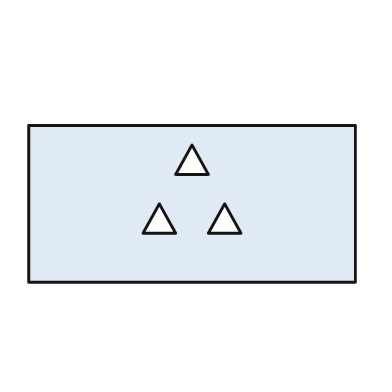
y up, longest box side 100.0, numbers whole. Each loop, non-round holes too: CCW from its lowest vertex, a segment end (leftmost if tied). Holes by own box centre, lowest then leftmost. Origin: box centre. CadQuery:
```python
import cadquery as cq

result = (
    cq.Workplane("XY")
    .moveTo(-50.0, -24.0)
    .lineTo(50.0, -24.0)
    .lineTo(50.0, 24.0)
    .lineTo(-50.0, 24.0)
    .close()
    .moveTo(-15.0, -9.0)
    .lineTo(-5.0, -9.0)
    .lineTo(-10.0, 0.0)
    .close()
    .moveTo(5.0, -9.0)
    .lineTo(15.0, -9.0)
    .lineTo(10.0, 0.0)
    .close()
    .moveTo(-5.0, 9.0)
    .lineTo(5.0, 9.0)
    .lineTo(0.0, 18.0)
    .close()
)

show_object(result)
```